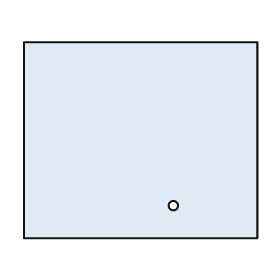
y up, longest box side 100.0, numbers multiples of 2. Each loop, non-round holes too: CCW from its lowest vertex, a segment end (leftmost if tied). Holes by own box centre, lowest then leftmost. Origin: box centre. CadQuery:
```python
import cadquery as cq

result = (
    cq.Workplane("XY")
    .moveTo(-50.0, -42.0)
    .lineTo(50.0, -42.0)
    .lineTo(50.0, 42.0)
    .lineTo(-50.0, 42.0)
    .close()
    .moveTo(14.0, -28.0)
    .circle(2.0)
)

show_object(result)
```